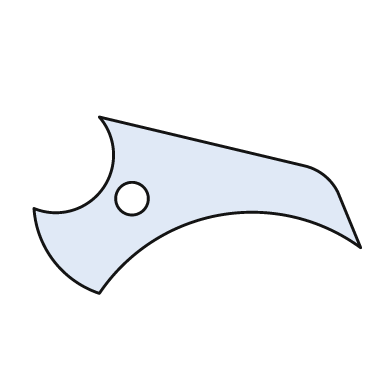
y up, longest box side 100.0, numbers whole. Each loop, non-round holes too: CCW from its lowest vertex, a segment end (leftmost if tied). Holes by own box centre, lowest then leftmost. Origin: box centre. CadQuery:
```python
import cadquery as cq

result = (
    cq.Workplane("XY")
    .moveTo(-30.0, -27.0)
    .threePointArc((7.0, -3.0), (50.0, -13.0))
    .lineTo(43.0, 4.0)
    .threePointArc((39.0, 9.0), (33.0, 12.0))
    .lineTo(-30.0, 27.0)
    .threePointArc((-29.0, 5.0), (-50.0, -1.0))
    .threePointArc((-44.0, -17.0), (-30.0, -27.0))
    .close()
    .moveTo(-20.0, 2.0)
    .circle(5.0)
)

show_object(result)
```